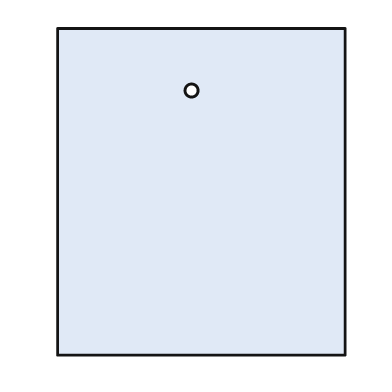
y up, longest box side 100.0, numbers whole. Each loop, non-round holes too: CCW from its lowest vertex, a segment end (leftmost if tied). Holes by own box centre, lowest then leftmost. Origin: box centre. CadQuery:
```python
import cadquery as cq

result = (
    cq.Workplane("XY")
    .moveTo(-44.0, -50.0)
    .lineTo(44.0, -50.0)
    .lineTo(44.0, 50.0)
    .lineTo(-44.0, 50.0)
    .close()
    .moveTo(-3.0, 31.0)
    .circle(2.0)
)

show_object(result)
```